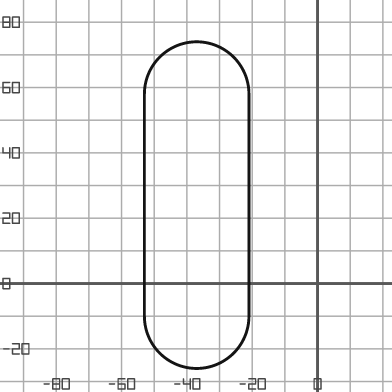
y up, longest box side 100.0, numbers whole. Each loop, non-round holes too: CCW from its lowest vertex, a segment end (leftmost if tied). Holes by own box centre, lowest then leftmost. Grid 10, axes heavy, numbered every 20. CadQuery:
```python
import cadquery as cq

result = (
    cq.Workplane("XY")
    .moveTo(-53.0, -10.0)
    .threePointArc((-37.0, -26.0), (-21.0, -10.0))
    .lineTo(-21.0, 58.0)
    .threePointArc((-37.0, 74.0), (-53.0, 58.0))
    .close()
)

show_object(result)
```